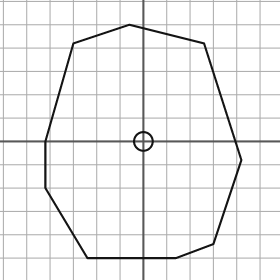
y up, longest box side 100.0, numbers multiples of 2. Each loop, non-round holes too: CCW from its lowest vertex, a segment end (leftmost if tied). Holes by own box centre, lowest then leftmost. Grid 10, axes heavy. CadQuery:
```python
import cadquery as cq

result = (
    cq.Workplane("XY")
    .moveTo(-24.0, -50.0)
    .lineTo(14.0, -50.0)
    .lineTo(30.0, -44.0)
    .lineTo(42.0, -8.0)
    .lineTo(26.0, 42.0)
    .lineTo(-6.0, 50.0)
    .lineTo(-30.0, 42.0)
    .lineTo(-42.0, 0.0)
    .lineTo(-42.0, -20.0)
    .close()
    .moveTo(0.0, 0.0)
    .circle(4.0)
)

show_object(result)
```